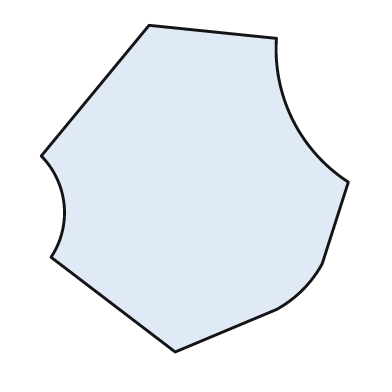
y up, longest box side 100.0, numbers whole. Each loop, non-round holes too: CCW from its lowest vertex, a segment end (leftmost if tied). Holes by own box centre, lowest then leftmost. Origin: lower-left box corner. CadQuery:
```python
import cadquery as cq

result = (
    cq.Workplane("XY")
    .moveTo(41.0, 0.0)
    .lineTo(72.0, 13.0)
    .threePointArc((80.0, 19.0), (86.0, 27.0))
    .lineTo(94.0, 52.0)
    .threePointArc((77.0, 71.0), (72.0, 96.0))
    .lineTo(33.0, 100.0)
    .lineTo(0.0, 60.0)
    .threePointArc((7.0, 45.0), (3.0, 29.0))
    .close()
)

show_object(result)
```